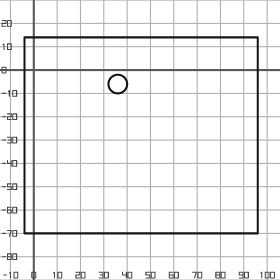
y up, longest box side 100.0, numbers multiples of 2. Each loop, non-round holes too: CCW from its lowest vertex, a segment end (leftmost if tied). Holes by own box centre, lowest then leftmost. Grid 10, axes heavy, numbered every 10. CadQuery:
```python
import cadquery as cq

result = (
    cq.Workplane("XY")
    .moveTo(-4.0, -70.0)
    .lineTo(96.0, -70.0)
    .lineTo(96.0, 14.0)
    .lineTo(-4.0, 14.0)
    .close()
    .moveTo(36.0, -6.0)
    .circle(4.0)
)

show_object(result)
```